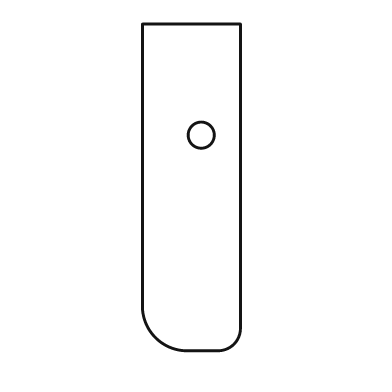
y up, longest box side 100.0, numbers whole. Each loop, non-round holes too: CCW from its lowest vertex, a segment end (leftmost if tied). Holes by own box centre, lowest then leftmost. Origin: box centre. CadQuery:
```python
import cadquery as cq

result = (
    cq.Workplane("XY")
    .moveTo(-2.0, -50.0)
    .lineTo(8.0, -50.0)
    .threePointArc((13.0, -48.0), (15.0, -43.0))
    .lineTo(15.0, 50.0)
    .lineTo(-15.0, 50.0)
    .lineTo(-15.0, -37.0)
    .threePointArc((-11.0, -46.0), (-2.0, -50.0))
    .close()
    .moveTo(3.0, 16.0)
    .circle(4.0)
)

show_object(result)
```